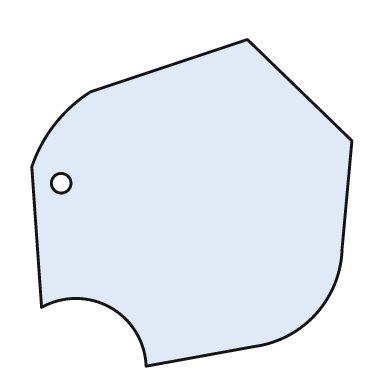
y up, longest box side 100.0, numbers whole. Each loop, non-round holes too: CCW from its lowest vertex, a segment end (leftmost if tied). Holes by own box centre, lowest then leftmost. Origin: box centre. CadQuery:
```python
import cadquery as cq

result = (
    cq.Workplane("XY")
    .moveTo(-14.0, -50.0)
    .lineTo(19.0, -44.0)
    .threePointArc((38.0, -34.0), (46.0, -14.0))
    .lineTo(49.0, 19.0)
    .lineTo(17.0, 50.0)
    .lineTo(-31.0, 34.0)
    .threePointArc((-42.0, 24.0), (-49.0, 11.0))
    .lineTo(-46.0, -32.0)
    .threePointArc((-25.0, -32.0), (-14.0, -50.0))
    .close()
    .moveTo(-40.0, 6.0)
    .circle(3.0)
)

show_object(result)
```